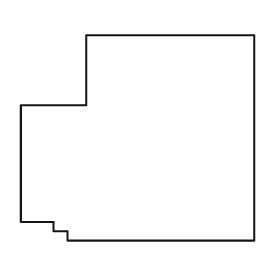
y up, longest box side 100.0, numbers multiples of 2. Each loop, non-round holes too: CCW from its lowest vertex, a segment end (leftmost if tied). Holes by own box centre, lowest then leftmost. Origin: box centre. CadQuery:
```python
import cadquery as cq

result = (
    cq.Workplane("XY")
    .moveTo(-30.0, -44.0)
    .lineTo(50.0, -44.0)
    .lineTo(50.0, 44.0)
    .lineTo(-22.0, 44.0)
    .lineTo(-22.0, 14.0)
    .lineTo(-50.0, 14.0)
    .lineTo(-50.0, -36.0)
    .lineTo(-36.0, -36.0)
    .lineTo(-36.0, -40.0)
    .lineTo(-30.0, -40.0)
    .close()
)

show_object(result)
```